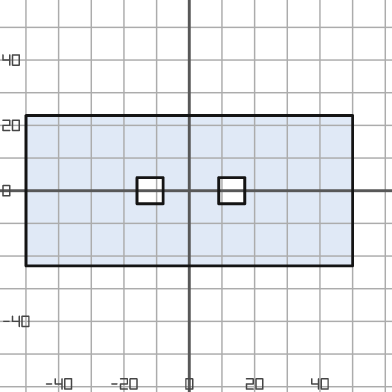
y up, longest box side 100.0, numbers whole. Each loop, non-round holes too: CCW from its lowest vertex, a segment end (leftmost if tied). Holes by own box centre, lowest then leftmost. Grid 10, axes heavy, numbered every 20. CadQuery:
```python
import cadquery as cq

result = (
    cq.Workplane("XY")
    .moveTo(-50.0, -23.0)
    .lineTo(50.0, -23.0)
    .lineTo(50.0, 23.0)
    .lineTo(-50.0, 23.0)
    .close()
    .moveTo(-16.0, -4.0)
    .lineTo(-8.0, -4.0)
    .lineTo(-8.0, 4.0)
    .lineTo(-16.0, 4.0)
    .close()
    .moveTo(9.0, -4.0)
    .lineTo(17.0, -4.0)
    .lineTo(17.0, 4.0)
    .lineTo(9.0, 4.0)
    .close()
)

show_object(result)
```